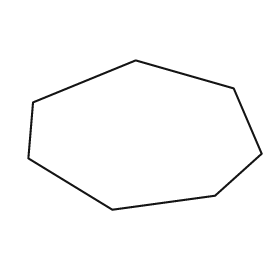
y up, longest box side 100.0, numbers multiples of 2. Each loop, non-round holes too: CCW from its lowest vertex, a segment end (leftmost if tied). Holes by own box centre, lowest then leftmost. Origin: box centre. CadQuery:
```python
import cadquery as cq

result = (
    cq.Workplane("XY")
    .moveTo(-14.0, -32.0)
    .lineTo(30.0, -26.0)
    .lineTo(50.0, -8.0)
    .lineTo(38.0, 20.0)
    .lineTo(-4.0, 32.0)
    .lineTo(-48.0, 14.0)
    .lineTo(-50.0, -10.0)
    .close()
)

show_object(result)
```